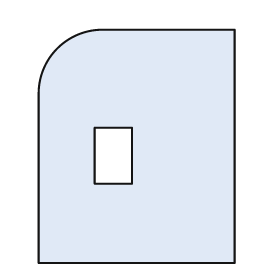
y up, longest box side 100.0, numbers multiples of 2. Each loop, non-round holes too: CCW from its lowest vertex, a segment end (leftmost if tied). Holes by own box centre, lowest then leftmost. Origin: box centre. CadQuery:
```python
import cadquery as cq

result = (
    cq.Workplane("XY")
    .moveTo(-42.0, -50.0)
    .lineTo(42.0, -50.0)
    .lineTo(42.0, 50.0)
    .lineTo(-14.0, 50.0)
    .threePointArc((-34.0, 42.0), (-42.0, 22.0))
    .close()
    .moveTo(-18.0, -16.0)
    .lineTo(-2.0, -16.0)
    .lineTo(-2.0, 8.0)
    .lineTo(-18.0, 8.0)
    .close()
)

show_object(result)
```